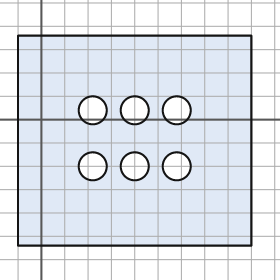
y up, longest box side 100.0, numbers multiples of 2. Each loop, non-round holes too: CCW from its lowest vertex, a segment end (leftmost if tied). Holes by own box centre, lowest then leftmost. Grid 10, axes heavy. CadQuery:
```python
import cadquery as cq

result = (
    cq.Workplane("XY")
    .moveTo(-10.0, -54.0)
    .lineTo(90.0, -54.0)
    .lineTo(90.0, 36.0)
    .lineTo(-10.0, 36.0)
    .close()
    .moveTo(22.0, -20.0)
    .circle(6.0)
    .moveTo(40.0, -20.0)
    .circle(6.0)
    .moveTo(58.0, -20.0)
    .circle(6.0)
    .moveTo(22.0, 4.0)
    .circle(6.0)
    .moveTo(40.0, 4.0)
    .circle(6.0)
    .moveTo(58.0, 4.0)
    .circle(6.0)
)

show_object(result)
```